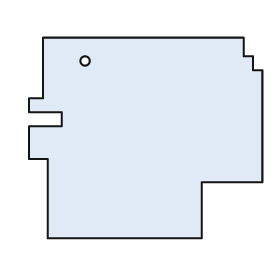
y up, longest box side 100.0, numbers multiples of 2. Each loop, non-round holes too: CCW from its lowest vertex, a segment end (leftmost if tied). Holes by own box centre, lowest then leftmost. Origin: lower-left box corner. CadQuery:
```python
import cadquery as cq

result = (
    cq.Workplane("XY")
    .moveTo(8.0, 0.0)
    .lineTo(74.0, 0.0)
    .lineTo(74.0, 24.0)
    .lineTo(100.0, 24.0)
    .lineTo(100.0, 72.0)
    .lineTo(96.0, 72.0)
    .lineTo(96.0, 78.0)
    .lineTo(92.0, 78.0)
    .lineTo(92.0, 86.0)
    .lineTo(6.0, 86.0)
    .lineTo(6.0, 60.0)
    .lineTo(0.0, 60.0)
    .lineTo(0.0, 54.0)
    .lineTo(14.0, 54.0)
    .lineTo(14.0, 48.0)
    .lineTo(0.0, 48.0)
    .lineTo(0.0, 34.0)
    .lineTo(8.0, 34.0)
    .close()
    .moveTo(24.0, 76.0)
    .circle(2.0)
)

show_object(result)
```